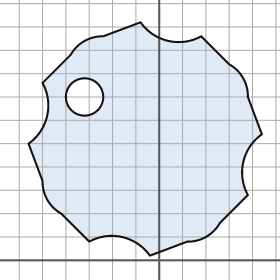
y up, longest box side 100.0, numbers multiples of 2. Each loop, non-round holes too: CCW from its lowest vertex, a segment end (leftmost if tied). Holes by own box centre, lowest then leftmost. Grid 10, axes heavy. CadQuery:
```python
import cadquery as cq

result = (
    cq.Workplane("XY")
    .moveTo(-4.0, 2.0)
    .lineTo(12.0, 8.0)
    .threePointArc((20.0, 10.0), (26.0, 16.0))
    .lineTo(38.0, 28.0)
    .threePointArc((36.0, 42.0), (44.0, 54.0))
    .lineTo(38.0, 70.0)
    .threePointArc((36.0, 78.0), (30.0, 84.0))
    .lineTo(18.0, 96.0)
    .threePointArc((4.0, 94.0), (-8.0, 102.0))
    .lineTo(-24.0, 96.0)
    .threePointArc((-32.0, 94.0), (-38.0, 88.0))
    .lineTo(-50.0, 76.0)
    .threePointArc((-48.0, 62.0), (-56.0, 50.0))
    .lineTo(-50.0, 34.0)
    .threePointArc((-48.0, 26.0), (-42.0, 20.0))
    .lineTo(-30.0, 8.0)
    .threePointArc((-16.0, 10.0), (-4.0, 2.0))
    .close()
    .moveTo(-32.0, 70.0)
    .circle(8.0)
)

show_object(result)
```